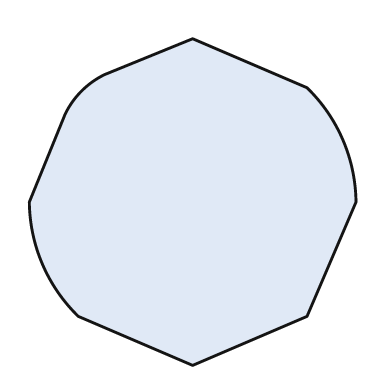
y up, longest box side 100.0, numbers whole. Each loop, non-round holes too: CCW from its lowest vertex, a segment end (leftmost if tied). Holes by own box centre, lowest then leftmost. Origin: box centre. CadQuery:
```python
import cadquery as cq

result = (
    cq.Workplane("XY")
    .moveTo(0.0, -50.0)
    .lineTo(35.0, -35.0)
    .lineTo(50.0, 0.0)
    .threePointArc((46.0, 19.0), (35.0, 35.0))
    .lineTo(0.0, 50.0)
    .lineTo(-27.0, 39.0)
    .threePointArc((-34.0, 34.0), (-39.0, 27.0))
    .lineTo(-50.0, 0.0)
    .threePointArc((-46.0, -19.0), (-35.0, -35.0))
    .close()
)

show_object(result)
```